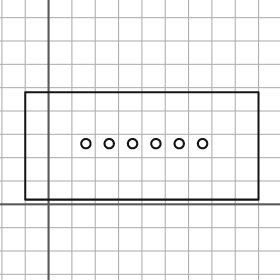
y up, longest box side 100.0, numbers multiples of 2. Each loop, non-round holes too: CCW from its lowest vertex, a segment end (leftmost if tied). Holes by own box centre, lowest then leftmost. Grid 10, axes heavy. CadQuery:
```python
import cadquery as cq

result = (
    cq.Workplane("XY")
    .moveTo(-10.0, 2.0)
    .lineTo(90.0, 2.0)
    .lineTo(90.0, 48.0)
    .lineTo(-10.0, 48.0)
    .close()
    .moveTo(16.0, 26.0)
    .circle(2.0)
    .moveTo(26.0, 26.0)
    .circle(2.0)
    .moveTo(36.0, 26.0)
    .circle(2.0)
    .moveTo(46.0, 26.0)
    .circle(2.0)
    .moveTo(56.0, 26.0)
    .circle(2.0)
    .moveTo(66.0, 26.0)
    .circle(2.0)
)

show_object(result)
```